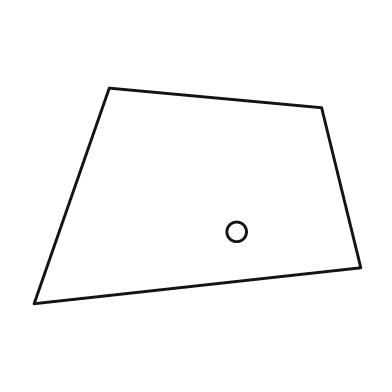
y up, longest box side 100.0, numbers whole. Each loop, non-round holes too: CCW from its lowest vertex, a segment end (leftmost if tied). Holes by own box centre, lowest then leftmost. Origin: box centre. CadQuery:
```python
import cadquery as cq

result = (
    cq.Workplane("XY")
    .moveTo(-50.0, -33.0)
    .lineTo(50.0, -22.0)
    .lineTo(38.0, 27.0)
    .lineTo(-27.0, 33.0)
    .close()
    .moveTo(12.0, -11.0)
    .circle(3.0)
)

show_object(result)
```